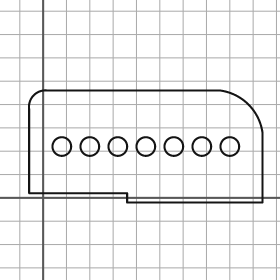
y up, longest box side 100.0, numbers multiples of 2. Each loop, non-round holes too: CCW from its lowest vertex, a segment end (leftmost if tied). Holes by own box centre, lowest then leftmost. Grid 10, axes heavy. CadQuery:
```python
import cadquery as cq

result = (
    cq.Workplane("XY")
    .moveTo(36.0, -2.0)
    .lineTo(94.0, -2.0)
    .lineTo(94.0, 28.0)
    .threePointArc((88.0, 40.0), (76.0, 46.0))
    .lineTo(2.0, 46.0)
    .threePointArc((-4.0, 44.0), (-6.0, 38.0))
    .lineTo(-6.0, 2.0)
    .lineTo(36.0, 2.0)
    .close()
    .moveTo(8.0, 22.0)
    .circle(4.0)
    .moveTo(20.0, 22.0)
    .circle(4.0)
    .moveTo(32.0, 22.0)
    .circle(4.0)
    .moveTo(44.0, 22.0)
    .circle(4.0)
    .moveTo(56.0, 22.0)
    .circle(4.0)
    .moveTo(68.0, 22.0)
    .circle(4.0)
    .moveTo(80.0, 22.0)
    .circle(4.0)
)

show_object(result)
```